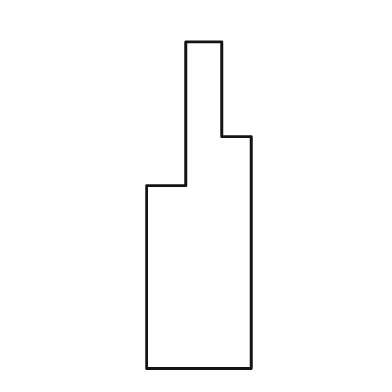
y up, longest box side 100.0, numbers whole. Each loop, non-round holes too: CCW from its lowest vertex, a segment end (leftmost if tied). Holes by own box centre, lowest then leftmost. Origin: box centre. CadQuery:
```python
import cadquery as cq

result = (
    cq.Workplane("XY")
    .moveTo(-16.0, -50.0)
    .lineTo(16.0, -50.0)
    .lineTo(16.0, 21.0)
    .lineTo(7.0, 21.0)
    .lineTo(7.0, 50.0)
    .lineTo(-4.0, 50.0)
    .lineTo(-4.0, 6.0)
    .lineTo(-16.0, 6.0)
    .close()
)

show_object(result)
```